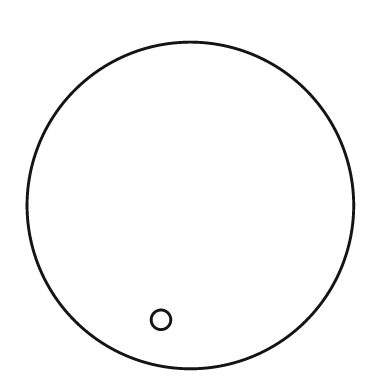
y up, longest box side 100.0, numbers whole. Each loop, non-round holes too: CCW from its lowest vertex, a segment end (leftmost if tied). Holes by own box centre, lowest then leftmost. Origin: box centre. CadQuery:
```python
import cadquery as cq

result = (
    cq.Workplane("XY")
    .moveTo(0.0, 0.0)
    .circle(50.0)
    .moveTo(-9.0, -35.0)
    .circle(3.0)
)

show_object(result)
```